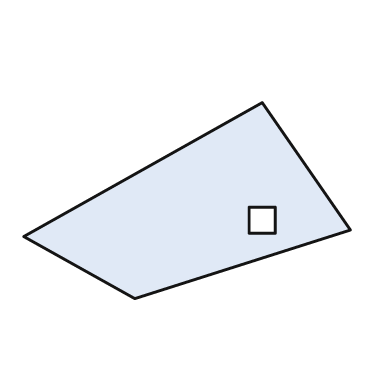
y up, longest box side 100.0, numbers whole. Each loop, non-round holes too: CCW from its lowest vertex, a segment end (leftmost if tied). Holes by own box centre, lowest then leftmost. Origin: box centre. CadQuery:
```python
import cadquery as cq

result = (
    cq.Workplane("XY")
    .moveTo(-16.0, -30.0)
    .lineTo(50.0, -9.0)
    .lineTo(23.0, 30.0)
    .lineTo(-50.0, -11.0)
    .close()
    .moveTo(19.0, -10.0)
    .lineTo(27.0, -10.0)
    .lineTo(27.0, -2.0)
    .lineTo(19.0, -2.0)
    .close()
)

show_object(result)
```